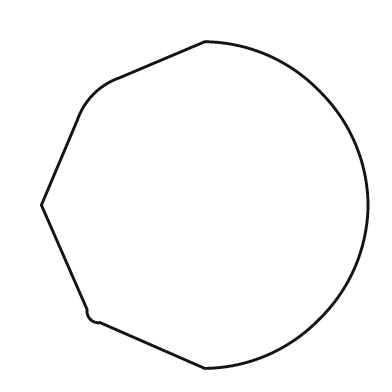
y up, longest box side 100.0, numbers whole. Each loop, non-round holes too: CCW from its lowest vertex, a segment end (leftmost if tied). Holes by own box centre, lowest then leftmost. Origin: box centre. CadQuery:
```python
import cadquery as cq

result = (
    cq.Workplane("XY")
    .moveTo(0.0, -50.0)
    .threePointArc((19.0, -46.0), (35.0, -35.0))
    .threePointArc((46.0, -19.0), (50.0, 0.0))
    .threePointArc((46.0, 19.0), (35.0, 35.0))
    .threePointArc((19.0, 46.0), (0.0, 50.0))
    .lineTo(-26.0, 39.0)
    .threePointArc((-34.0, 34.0), (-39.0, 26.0))
    .lineTo(-50.0, 0.0)
    .lineTo(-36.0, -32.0)
    .threePointArc((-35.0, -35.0), (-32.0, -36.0))
    .close()
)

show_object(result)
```